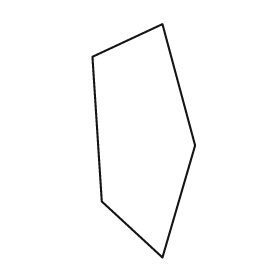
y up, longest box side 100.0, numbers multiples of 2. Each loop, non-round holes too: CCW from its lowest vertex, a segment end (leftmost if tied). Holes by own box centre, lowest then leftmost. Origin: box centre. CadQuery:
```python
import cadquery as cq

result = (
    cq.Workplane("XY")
    .moveTo(8.0, -50.0)
    .lineTo(22.0, -2.0)
    .lineTo(8.0, 50.0)
    .lineTo(-22.0, 36.0)
    .lineTo(-18.0, -26.0)
    .close()
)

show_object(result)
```